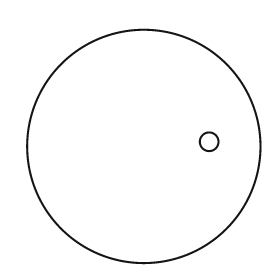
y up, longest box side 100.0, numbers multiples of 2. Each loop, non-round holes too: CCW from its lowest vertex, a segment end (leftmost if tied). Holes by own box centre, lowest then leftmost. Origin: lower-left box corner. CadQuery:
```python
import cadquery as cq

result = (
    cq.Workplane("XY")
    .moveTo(50.0, 50.0)
    .circle(50.0)
    .moveTo(78.0, 52.0)
    .circle(4.0)
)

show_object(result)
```